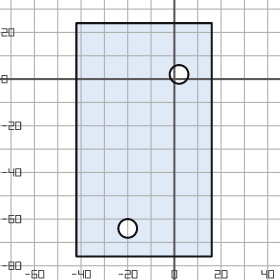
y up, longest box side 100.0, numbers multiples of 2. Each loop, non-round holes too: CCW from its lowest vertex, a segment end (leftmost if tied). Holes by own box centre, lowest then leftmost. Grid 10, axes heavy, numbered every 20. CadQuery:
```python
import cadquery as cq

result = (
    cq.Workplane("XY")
    .moveTo(-42.0, -76.0)
    .lineTo(16.0, -76.0)
    .lineTo(16.0, 24.0)
    .lineTo(-42.0, 24.0)
    .close()
    .moveTo(-20.0, -64.0)
    .circle(4.0)
    .moveTo(2.0, 2.0)
    .circle(4.0)
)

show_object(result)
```